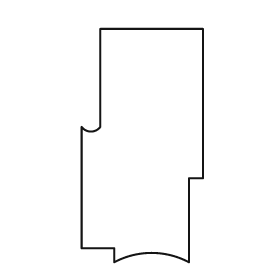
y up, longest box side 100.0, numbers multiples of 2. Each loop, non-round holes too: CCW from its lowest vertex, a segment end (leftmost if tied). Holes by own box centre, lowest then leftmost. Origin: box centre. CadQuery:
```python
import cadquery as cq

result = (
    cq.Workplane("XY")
    .moveTo(-12.0, -50.0)
    .threePointArc((4.0, -46.0), (20.0, -50.0))
    .lineTo(20.0, -14.0)
    .lineTo(26.0, -14.0)
    .lineTo(26.0, 50.0)
    .lineTo(-18.0, 50.0)
    .lineTo(-18.0, 8.0)
    .threePointArc((-22.0, 6.0), (-26.0, 8.0))
    .lineTo(-26.0, -44.0)
    .lineTo(-12.0, -44.0)
    .close()
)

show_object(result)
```